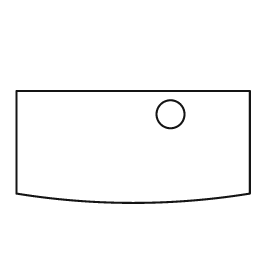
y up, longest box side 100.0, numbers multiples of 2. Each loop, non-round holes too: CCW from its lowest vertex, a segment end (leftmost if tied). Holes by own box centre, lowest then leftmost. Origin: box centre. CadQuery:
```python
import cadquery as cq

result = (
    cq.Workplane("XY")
    .moveTo(-50.0, -20.0)
    .threePointArc((0.0, -24.0), (50.0, -20.0))
    .lineTo(50.0, 24.0)
    .lineTo(-50.0, 24.0)
    .close()
    .moveTo(16.0, 14.0)
    .circle(6.0)
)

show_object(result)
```